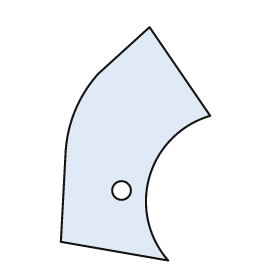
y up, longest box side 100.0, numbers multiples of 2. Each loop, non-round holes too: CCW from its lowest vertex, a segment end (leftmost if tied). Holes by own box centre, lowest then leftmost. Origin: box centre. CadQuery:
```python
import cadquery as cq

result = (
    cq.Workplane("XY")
    .moveTo(14.0, -50.0)
    .threePointArc((6.0, -14.0), (32.0, 12.0))
    .lineTo(6.0, 50.0)
    .lineTo(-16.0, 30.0)
    .threePointArc((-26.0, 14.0), (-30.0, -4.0))
    .lineTo(-32.0, -42.0)
    .close()
    .moveTo(-6.0, -20.0)
    .circle(4.0)
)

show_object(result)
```